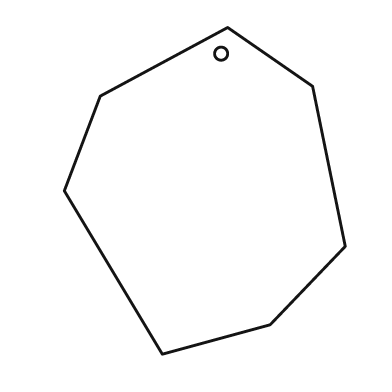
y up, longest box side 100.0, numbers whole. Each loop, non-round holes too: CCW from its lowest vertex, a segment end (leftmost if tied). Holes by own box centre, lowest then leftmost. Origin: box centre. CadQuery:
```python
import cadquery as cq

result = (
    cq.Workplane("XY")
    .moveTo(-13.0, -50.0)
    .lineTo(20.0, -41.0)
    .lineTo(43.0, -17.0)
    .lineTo(33.0, 32.0)
    .lineTo(7.0, 50.0)
    .lineTo(-32.0, 29.0)
    .lineTo(-43.0, 0.0)
    .close()
    .moveTo(5.0, 42.0)
    .circle(2.0)
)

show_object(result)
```